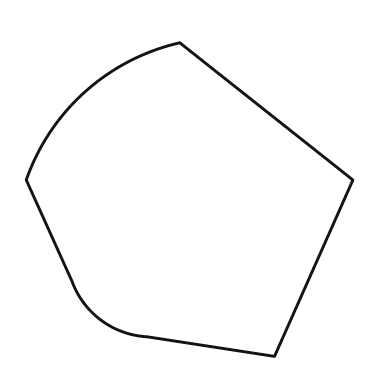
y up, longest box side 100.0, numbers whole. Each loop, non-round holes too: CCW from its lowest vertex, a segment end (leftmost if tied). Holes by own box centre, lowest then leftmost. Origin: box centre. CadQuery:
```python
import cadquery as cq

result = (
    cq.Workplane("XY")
    .moveTo(26.0, -48.0)
    .lineTo(50.0, 6.0)
    .lineTo(-3.0, 48.0)
    .threePointArc((-32.0, 33.0), (-50.0, 6.0))
    .lineTo(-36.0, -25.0)
    .threePointArc((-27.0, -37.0), (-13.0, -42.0))
    .close()
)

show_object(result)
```